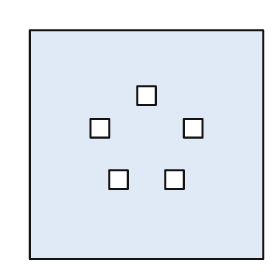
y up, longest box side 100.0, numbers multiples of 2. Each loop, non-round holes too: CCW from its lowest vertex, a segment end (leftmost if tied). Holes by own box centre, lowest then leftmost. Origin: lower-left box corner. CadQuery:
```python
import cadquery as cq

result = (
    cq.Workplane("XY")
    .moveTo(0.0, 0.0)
    .lineTo(100.0, 0.0)
    .lineTo(100.0, 98.0)
    .lineTo(0.0, 98.0)
    .close()
    .moveTo(34.0, 30.0)
    .lineTo(42.0, 30.0)
    .lineTo(42.0, 38.0)
    .lineTo(34.0, 38.0)
    .close()
    .moveTo(58.0, 30.0)
    .lineTo(66.0, 30.0)
    .lineTo(66.0, 38.0)
    .lineTo(58.0, 38.0)
    .close()
    .moveTo(26.0, 52.0)
    .lineTo(34.0, 52.0)
    .lineTo(34.0, 60.0)
    .lineTo(26.0, 60.0)
    .close()
    .moveTo(66.0, 52.0)
    .lineTo(74.0, 52.0)
    .lineTo(74.0, 60.0)
    .lineTo(66.0, 60.0)
    .close()
    .moveTo(46.0, 66.0)
    .lineTo(54.0, 66.0)
    .lineTo(54.0, 74.0)
    .lineTo(46.0, 74.0)
    .close()
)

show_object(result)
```